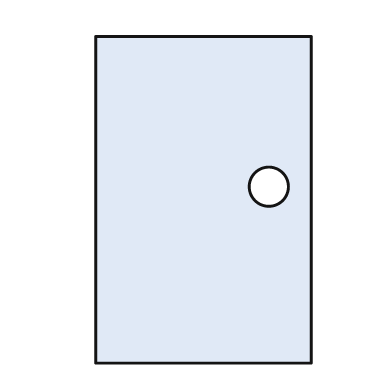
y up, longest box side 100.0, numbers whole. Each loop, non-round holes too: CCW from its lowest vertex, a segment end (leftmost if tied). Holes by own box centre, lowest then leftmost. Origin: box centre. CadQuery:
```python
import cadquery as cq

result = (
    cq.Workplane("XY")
    .moveTo(-33.0, -50.0)
    .lineTo(33.0, -50.0)
    .lineTo(33.0, 50.0)
    .lineTo(-33.0, 50.0)
    .close()
    .moveTo(20.0, 4.0)
    .circle(6.0)
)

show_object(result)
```